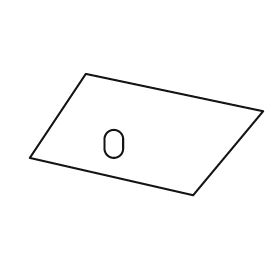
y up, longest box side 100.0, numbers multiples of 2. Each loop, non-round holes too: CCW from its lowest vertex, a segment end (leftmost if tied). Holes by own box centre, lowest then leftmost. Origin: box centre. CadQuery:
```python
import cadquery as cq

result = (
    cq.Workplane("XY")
    .moveTo(20.0, -26.0)
    .lineTo(50.0, 10.0)
    .lineTo(-26.0, 26.0)
    .lineTo(-50.0, -10.0)
    .close()
    .moveTo(-18.0, -6.0)
    .threePointArc((-14.0, -10.0), (-10.0, -6.0))
    .lineTo(-10.0, -2.0)
    .threePointArc((-14.0, 2.0), (-18.0, -2.0))
    .close()
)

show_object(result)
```